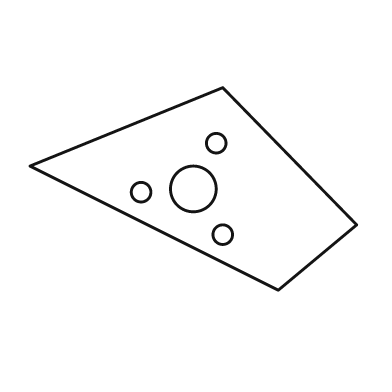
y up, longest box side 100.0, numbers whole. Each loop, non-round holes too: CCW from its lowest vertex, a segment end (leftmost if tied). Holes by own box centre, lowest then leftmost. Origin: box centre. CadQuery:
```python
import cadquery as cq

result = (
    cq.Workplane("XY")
    .moveTo(26.0, -31.0)
    .lineTo(50.0, -11.0)
    .lineTo(9.0, 31.0)
    .lineTo(-50.0, 7.0)
    .close()
    .moveTo(9.0, -14.0)
    .circle(3.0)
    .moveTo(-16.0, -1.0)
    .circle(3.0)
    .moveTo(0.0, 0.0)
    .circle(7.0)
    .moveTo(7.0, 14.0)
    .circle(3.0)
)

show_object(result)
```